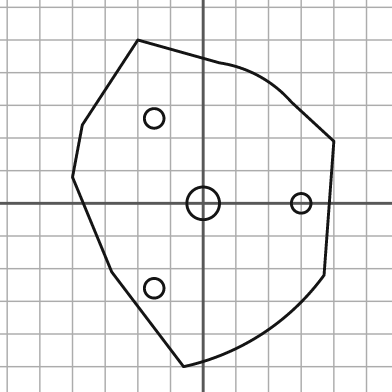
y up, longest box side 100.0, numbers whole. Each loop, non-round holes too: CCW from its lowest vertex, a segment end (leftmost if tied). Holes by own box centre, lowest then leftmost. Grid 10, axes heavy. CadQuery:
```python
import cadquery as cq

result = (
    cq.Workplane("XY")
    .moveTo(-6.0, -50.0)
    .threePointArc((18.0, -40.0), (37.0, -22.0))
    .lineTo(40.0, 19.0)
    .lineTo(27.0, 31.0)
    .threePointArc((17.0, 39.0), (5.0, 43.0))
    .lineTo(-20.0, 50.0)
    .lineTo(-37.0, 24.0)
    .lineTo(-40.0, 8.0)
    .lineTo(-28.0, -21.0)
    .close()
    .moveTo(-15.0, -26.0)
    .circle(3.0)
    .moveTo(0.0, 0.0)
    .circle(5.0)
    .moveTo(30.0, 0.0)
    .circle(3.0)
    .moveTo(-15.0, 26.0)
    .circle(3.0)
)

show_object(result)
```